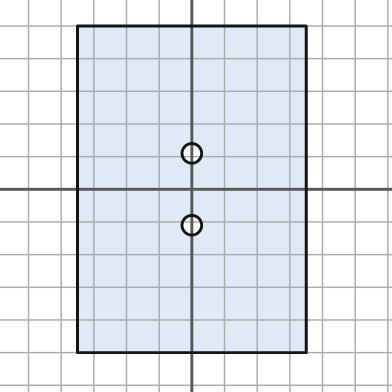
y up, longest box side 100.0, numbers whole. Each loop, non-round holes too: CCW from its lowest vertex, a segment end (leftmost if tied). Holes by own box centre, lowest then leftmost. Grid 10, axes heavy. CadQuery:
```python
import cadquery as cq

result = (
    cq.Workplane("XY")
    .moveTo(-35.0, -50.0)
    .lineTo(35.0, -50.0)
    .lineTo(35.0, 50.0)
    .lineTo(-35.0, 50.0)
    .close()
    .moveTo(0.0, -11.0)
    .circle(3.0)
    .moveTo(0.0, 11.0)
    .circle(3.0)
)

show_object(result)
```